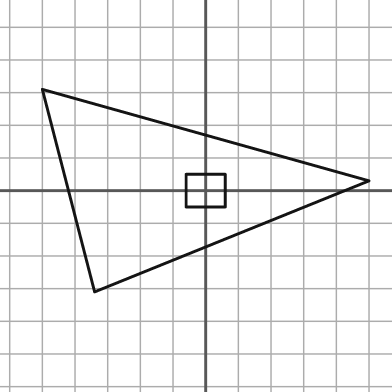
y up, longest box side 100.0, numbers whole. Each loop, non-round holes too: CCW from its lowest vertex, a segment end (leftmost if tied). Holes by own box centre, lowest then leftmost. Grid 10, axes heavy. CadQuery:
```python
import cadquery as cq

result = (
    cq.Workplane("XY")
    .moveTo(-34.0, -31.0)
    .lineTo(50.0, 3.0)
    .lineTo(-50.0, 31.0)
    .close()
    .moveTo(-6.0, -5.0)
    .lineTo(6.0, -5.0)
    .lineTo(6.0, 5.0)
    .lineTo(-6.0, 5.0)
    .close()
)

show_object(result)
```